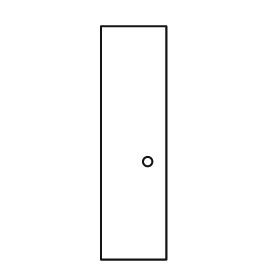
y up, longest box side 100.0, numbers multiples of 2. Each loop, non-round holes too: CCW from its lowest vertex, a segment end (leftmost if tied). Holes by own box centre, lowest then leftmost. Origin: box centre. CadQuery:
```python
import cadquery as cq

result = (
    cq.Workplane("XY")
    .moveTo(-14.0, -50.0)
    .lineTo(14.0, -50.0)
    .lineTo(14.0, 50.0)
    .lineTo(-14.0, 50.0)
    .close()
    .moveTo(6.0, -8.0)
    .circle(2.0)
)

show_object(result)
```